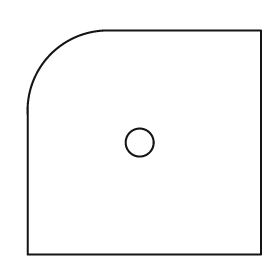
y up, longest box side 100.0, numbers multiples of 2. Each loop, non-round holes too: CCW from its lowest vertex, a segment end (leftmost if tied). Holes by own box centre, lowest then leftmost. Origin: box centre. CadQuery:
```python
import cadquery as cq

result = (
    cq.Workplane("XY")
    .moveTo(-50.0, -48.0)
    .lineTo(50.0, -48.0)
    .lineTo(50.0, 48.0)
    .lineTo(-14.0, 48.0)
    .threePointArc((-40.0, 38.0), (-50.0, 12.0))
    .close()
    .moveTo(-2.0, 0.0)
    .circle(6.0)
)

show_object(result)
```